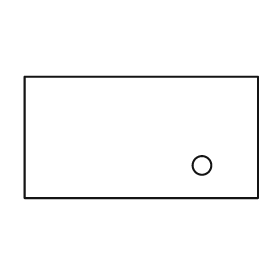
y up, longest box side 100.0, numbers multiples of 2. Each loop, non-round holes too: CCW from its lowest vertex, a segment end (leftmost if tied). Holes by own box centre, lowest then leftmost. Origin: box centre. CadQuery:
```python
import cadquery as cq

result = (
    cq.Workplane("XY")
    .moveTo(-50.0, -26.0)
    .lineTo(50.0, -26.0)
    .lineTo(50.0, 26.0)
    .lineTo(-50.0, 26.0)
    .close()
    .moveTo(26.0, -12.0)
    .circle(4.0)
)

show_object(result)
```